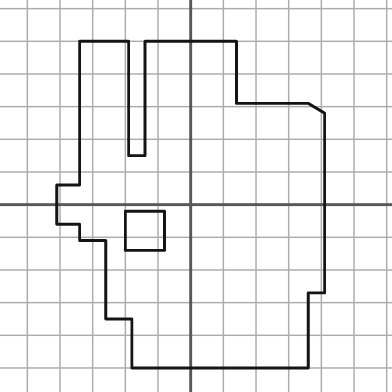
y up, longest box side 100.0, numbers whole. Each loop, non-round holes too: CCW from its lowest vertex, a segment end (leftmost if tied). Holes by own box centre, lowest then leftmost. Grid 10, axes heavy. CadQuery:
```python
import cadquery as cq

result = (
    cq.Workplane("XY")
    .moveTo(-18.0, -50.0)
    .lineTo(36.0, -50.0)
    .lineTo(36.0, -27.0)
    .lineTo(41.0, -27.0)
    .lineTo(41.0, 28.0)
    .lineTo(36.0, 31.0)
    .lineTo(14.0, 31.0)
    .lineTo(14.0, 50.0)
    .lineTo(-14.0, 50.0)
    .lineTo(-14.0, 15.0)
    .lineTo(-19.0, 15.0)
    .lineTo(-19.0, 50.0)
    .lineTo(-34.0, 50.0)
    .lineTo(-34.0, 6.0)
    .lineTo(-41.0, 6.0)
    .lineTo(-41.0, -6.0)
    .lineTo(-34.0, -6.0)
    .lineTo(-34.0, -11.0)
    .lineTo(-26.0, -11.0)
    .lineTo(-26.0, -35.0)
    .lineTo(-18.0, -35.0)
    .close()
    .moveTo(-20.0, -14.0)
    .lineTo(-8.0, -14.0)
    .lineTo(-8.0, -2.0)
    .lineTo(-20.0, -2.0)
    .close()
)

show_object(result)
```